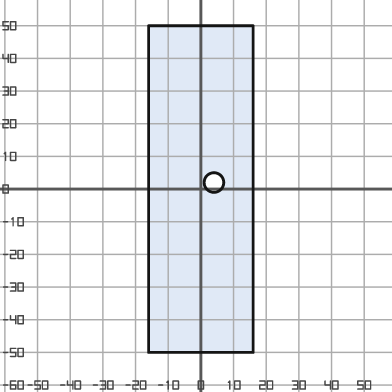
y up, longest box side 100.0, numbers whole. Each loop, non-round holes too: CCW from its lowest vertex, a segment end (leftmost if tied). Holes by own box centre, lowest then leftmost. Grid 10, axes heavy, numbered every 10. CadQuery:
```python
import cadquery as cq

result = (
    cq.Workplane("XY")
    .moveTo(-16.0, -50.0)
    .lineTo(16.0, -50.0)
    .lineTo(16.0, 50.0)
    .lineTo(-16.0, 50.0)
    .close()
    .moveTo(4.0, 2.0)
    .circle(3.0)
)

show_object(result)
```